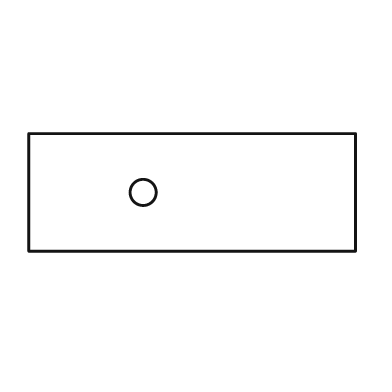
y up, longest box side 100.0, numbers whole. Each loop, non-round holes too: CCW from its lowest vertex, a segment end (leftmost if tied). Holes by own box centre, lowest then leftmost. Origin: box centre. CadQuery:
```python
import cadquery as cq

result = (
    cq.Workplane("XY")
    .moveTo(-50.0, -18.0)
    .lineTo(50.0, -18.0)
    .lineTo(50.0, 18.0)
    .lineTo(-50.0, 18.0)
    .close()
    .moveTo(-15.0, 0.0)
    .circle(4.0)
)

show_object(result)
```